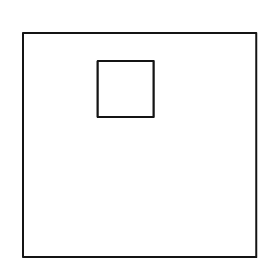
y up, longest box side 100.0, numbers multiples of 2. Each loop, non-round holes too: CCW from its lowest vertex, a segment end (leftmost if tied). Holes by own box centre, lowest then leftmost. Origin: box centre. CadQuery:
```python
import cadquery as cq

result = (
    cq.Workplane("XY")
    .moveTo(-50.0, -48.0)
    .lineTo(50.0, -48.0)
    .lineTo(50.0, 48.0)
    .lineTo(-50.0, 48.0)
    .close()
    .moveTo(-18.0, 12.0)
    .lineTo(6.0, 12.0)
    .lineTo(6.0, 36.0)
    .lineTo(-18.0, 36.0)
    .close()
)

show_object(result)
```